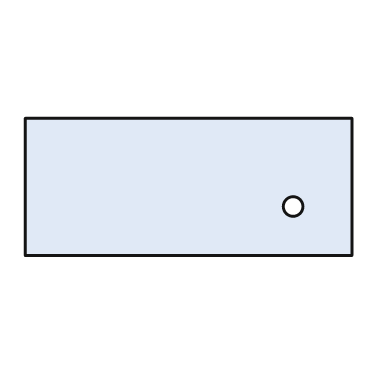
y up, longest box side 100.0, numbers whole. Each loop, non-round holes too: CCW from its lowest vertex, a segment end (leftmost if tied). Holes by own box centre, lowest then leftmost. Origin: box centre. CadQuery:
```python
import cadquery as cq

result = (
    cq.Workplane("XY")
    .moveTo(-50.0, -21.0)
    .lineTo(50.0, -21.0)
    .lineTo(50.0, 21.0)
    .lineTo(-50.0, 21.0)
    .close()
    .moveTo(32.0, -6.0)
    .circle(3.0)
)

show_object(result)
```